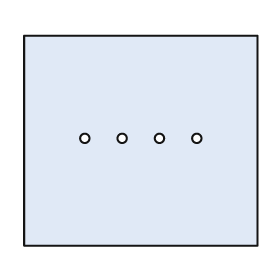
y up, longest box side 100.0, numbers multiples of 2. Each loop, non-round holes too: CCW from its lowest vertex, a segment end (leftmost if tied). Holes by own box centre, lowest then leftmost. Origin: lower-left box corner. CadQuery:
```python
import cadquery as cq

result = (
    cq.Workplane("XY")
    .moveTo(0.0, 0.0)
    .lineTo(100.0, 0.0)
    .lineTo(100.0, 90.0)
    .lineTo(0.0, 90.0)
    .close()
    .moveTo(26.0, 46.0)
    .circle(2.0)
    .moveTo(42.0, 46.0)
    .circle(2.0)
    .moveTo(58.0, 46.0)
    .circle(2.0)
    .moveTo(74.0, 46.0)
    .circle(2.0)
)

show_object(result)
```